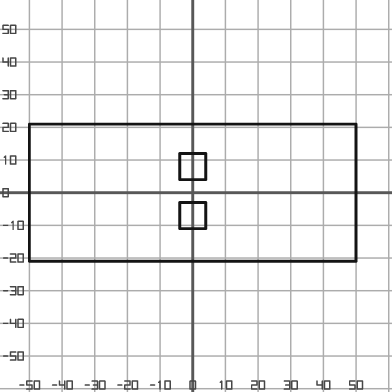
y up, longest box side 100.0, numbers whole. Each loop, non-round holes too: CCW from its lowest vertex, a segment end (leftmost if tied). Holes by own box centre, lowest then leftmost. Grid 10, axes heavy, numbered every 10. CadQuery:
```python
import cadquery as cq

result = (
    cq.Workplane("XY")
    .moveTo(-50.0, -21.0)
    .lineTo(50.0, -21.0)
    .lineTo(50.0, 21.0)
    .lineTo(-50.0, 21.0)
    .close()
    .moveTo(-4.0, -11.0)
    .lineTo(4.0, -11.0)
    .lineTo(4.0, -3.0)
    .lineTo(-4.0, -3.0)
    .close()
    .moveTo(-4.0, 4.0)
    .lineTo(4.0, 4.0)
    .lineTo(4.0, 12.0)
    .lineTo(-4.0, 12.0)
    .close()
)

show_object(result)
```